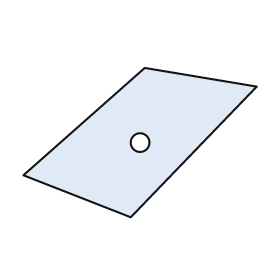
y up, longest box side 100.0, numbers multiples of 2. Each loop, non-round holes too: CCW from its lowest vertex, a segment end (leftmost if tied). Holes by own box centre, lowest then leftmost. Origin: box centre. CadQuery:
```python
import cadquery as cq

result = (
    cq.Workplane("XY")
    .moveTo(-4.0, -32.0)
    .lineTo(50.0, 24.0)
    .lineTo(2.0, 32.0)
    .lineTo(-50.0, -14.0)
    .close()
    .moveTo(0.0, 0.0)
    .circle(4.0)
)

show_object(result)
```